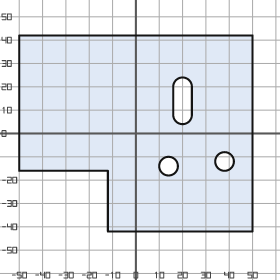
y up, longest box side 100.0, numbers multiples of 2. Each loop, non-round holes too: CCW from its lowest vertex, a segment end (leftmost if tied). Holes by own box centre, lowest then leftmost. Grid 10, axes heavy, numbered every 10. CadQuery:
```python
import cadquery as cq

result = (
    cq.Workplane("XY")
    .moveTo(-12.0, -42.0)
    .lineTo(50.0, -42.0)
    .lineTo(50.0, 42.0)
    .lineTo(-50.0, 42.0)
    .lineTo(-50.0, -16.0)
    .lineTo(-12.0, -16.0)
    .close()
    .moveTo(14.0, -14.0)
    .circle(4.0)
    .moveTo(38.0, -12.0)
    .circle(4.0)
    .moveTo(16.0, 8.0)
    .threePointArc((20.0, 4.0), (24.0, 8.0))
    .lineTo(24.0, 20.0)
    .threePointArc((20.0, 24.0), (16.0, 20.0))
    .close()
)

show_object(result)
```